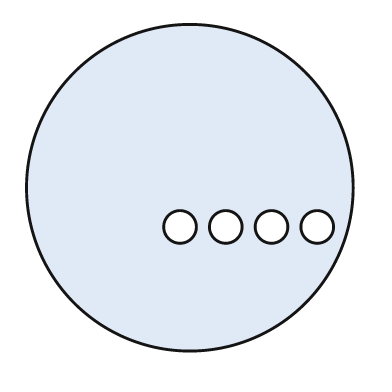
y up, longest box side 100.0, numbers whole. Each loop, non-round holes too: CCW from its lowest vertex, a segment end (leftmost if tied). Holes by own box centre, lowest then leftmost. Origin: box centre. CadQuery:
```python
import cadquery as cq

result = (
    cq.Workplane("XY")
    .moveTo(0.0, 0.0)
    .circle(50.0)
    .moveTo(-3.0, -12.0)
    .circle(5.0)
    .moveTo(11.0, -12.0)
    .circle(5.0)
    .moveTo(25.0, -12.0)
    .circle(5.0)
    .moveTo(39.0, -12.0)
    .circle(5.0)
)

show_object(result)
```